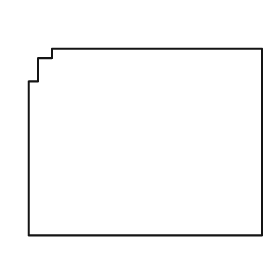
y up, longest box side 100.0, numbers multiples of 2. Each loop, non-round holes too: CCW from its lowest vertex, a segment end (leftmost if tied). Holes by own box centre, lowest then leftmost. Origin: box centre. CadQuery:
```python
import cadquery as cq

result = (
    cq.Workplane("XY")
    .moveTo(-50.0, -40.0)
    .lineTo(50.0, -40.0)
    .lineTo(50.0, 40.0)
    .lineTo(-40.0, 40.0)
    .lineTo(-40.0, 36.0)
    .lineTo(-46.0, 36.0)
    .lineTo(-46.0, 26.0)
    .lineTo(-50.0, 26.0)
    .close()
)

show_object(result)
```